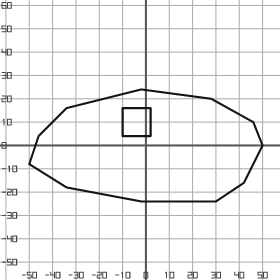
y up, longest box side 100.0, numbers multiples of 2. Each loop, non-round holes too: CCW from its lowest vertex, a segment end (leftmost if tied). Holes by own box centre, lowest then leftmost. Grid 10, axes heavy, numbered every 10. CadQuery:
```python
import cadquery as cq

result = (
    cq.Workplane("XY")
    .moveTo(-2.0, -24.0)
    .lineTo(30.0, -24.0)
    .lineTo(42.0, -16.0)
    .lineTo(50.0, 0.0)
    .lineTo(46.0, 10.0)
    .lineTo(28.0, 20.0)
    .lineTo(-2.0, 24.0)
    .lineTo(-34.0, 16.0)
    .lineTo(-46.0, 4.0)
    .lineTo(-50.0, -8.0)
    .lineTo(-34.0, -18.0)
    .close()
    .moveTo(-10.0, 4.0)
    .lineTo(2.0, 4.0)
    .lineTo(2.0, 16.0)
    .lineTo(-10.0, 16.0)
    .close()
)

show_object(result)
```